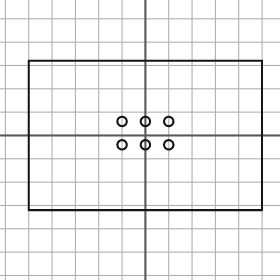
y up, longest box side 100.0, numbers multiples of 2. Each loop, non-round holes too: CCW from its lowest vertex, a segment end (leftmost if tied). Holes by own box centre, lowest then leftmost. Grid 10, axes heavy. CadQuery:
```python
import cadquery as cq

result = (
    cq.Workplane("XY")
    .moveTo(-50.0, -32.0)
    .lineTo(50.0, -32.0)
    .lineTo(50.0, 32.0)
    .lineTo(-50.0, 32.0)
    .close()
    .moveTo(-10.0, -4.0)
    .circle(2.0)
    .moveTo(0.0, -4.0)
    .circle(2.0)
    .moveTo(10.0, -4.0)
    .circle(2.0)
    .moveTo(-10.0, 6.0)
    .circle(2.0)
    .moveTo(0.0, 6.0)
    .circle(2.0)
    .moveTo(10.0, 6.0)
    .circle(2.0)
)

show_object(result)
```